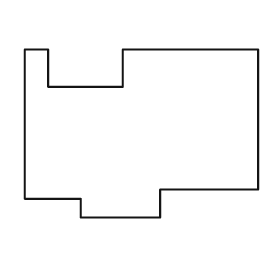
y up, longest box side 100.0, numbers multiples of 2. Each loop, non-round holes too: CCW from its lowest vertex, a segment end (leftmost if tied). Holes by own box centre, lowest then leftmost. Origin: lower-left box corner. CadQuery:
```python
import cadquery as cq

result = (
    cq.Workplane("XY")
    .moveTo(24.0, 0.0)
    .lineTo(58.0, 0.0)
    .lineTo(58.0, 12.0)
    .lineTo(100.0, 12.0)
    .lineTo(100.0, 72.0)
    .lineTo(42.0, 72.0)
    .lineTo(42.0, 56.0)
    .lineTo(10.0, 56.0)
    .lineTo(10.0, 72.0)
    .lineTo(0.0, 72.0)
    .lineTo(0.0, 8.0)
    .lineTo(24.0, 8.0)
    .close()
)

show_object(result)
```